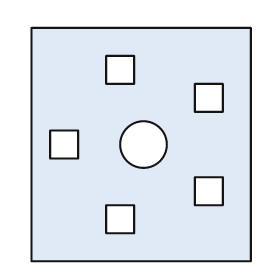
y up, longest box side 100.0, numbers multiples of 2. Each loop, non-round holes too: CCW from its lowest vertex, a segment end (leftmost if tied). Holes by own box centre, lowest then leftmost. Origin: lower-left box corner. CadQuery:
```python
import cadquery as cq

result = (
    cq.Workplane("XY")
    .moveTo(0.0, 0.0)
    .lineTo(94.0, 0.0)
    .lineTo(94.0, 100.0)
    .lineTo(0.0, 100.0)
    .close()
    .moveTo(32.0, 12.0)
    .lineTo(44.0, 12.0)
    .lineTo(44.0, 24.0)
    .lineTo(32.0, 24.0)
    .close()
    .moveTo(70.0, 24.0)
    .lineTo(82.0, 24.0)
    .lineTo(82.0, 36.0)
    .lineTo(70.0, 36.0)
    .close()
    .moveTo(8.0, 44.0)
    .lineTo(20.0, 44.0)
    .lineTo(20.0, 56.0)
    .lineTo(8.0, 56.0)
    .close()
    .moveTo(48.0, 50.0)
    .circle(10.0)
    .moveTo(70.0, 64.0)
    .lineTo(82.0, 64.0)
    .lineTo(82.0, 76.0)
    .lineTo(70.0, 76.0)
    .close()
    .moveTo(32.0, 76.0)
    .lineTo(44.0, 76.0)
    .lineTo(44.0, 88.0)
    .lineTo(32.0, 88.0)
    .close()
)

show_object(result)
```